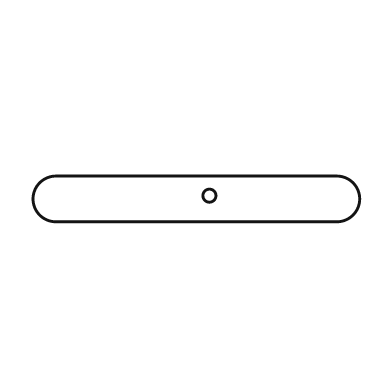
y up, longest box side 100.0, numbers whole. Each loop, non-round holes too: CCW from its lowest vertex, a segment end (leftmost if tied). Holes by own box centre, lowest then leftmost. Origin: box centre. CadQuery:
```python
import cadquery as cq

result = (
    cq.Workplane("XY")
    .moveTo(-43.0, -7.0)
    .lineTo(43.0, -7.0)
    .threePointArc((50.0, 0.0), (43.0, 7.0))
    .lineTo(-43.0, 7.0)
    .threePointArc((-50.0, 0.0), (-43.0, -7.0))
    .close()
    .moveTo(4.0, 1.0)
    .circle(2.0)
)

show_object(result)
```